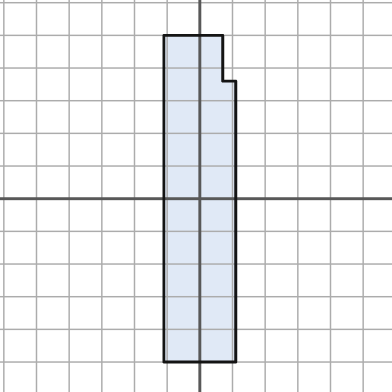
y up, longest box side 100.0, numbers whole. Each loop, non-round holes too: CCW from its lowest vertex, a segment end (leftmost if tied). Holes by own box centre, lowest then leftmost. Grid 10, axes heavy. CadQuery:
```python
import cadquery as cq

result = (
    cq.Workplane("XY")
    .moveTo(-11.0, -50.0)
    .lineTo(11.0, -50.0)
    .lineTo(11.0, 36.0)
    .lineTo(7.0, 36.0)
    .lineTo(7.0, 50.0)
    .lineTo(-11.0, 50.0)
    .close()
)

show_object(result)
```